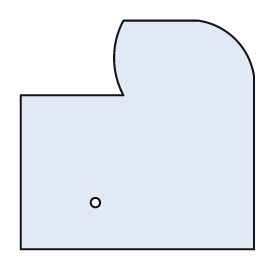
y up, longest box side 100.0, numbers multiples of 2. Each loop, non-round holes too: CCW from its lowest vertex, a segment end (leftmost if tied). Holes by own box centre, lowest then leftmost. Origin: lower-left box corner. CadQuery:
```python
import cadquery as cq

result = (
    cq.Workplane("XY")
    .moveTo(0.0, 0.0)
    .lineTo(100.0, 0.0)
    .lineTo(100.0, 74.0)
    .threePointArc((92.0, 90.0), (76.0, 98.0))
    .lineTo(44.0, 98.0)
    .threePointArc((40.0, 82.0), (44.0, 66.0))
    .lineTo(0.0, 66.0)
    .close()
    .moveTo(32.0, 20.0)
    .circle(2.0)
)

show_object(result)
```